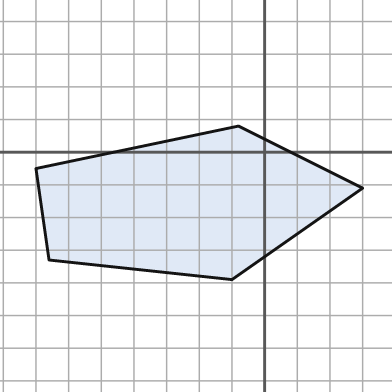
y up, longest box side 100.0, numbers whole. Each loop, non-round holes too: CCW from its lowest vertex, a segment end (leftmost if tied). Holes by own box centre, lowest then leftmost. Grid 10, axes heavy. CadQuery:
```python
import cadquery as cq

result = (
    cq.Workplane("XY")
    .moveTo(-10.0, -39.0)
    .lineTo(30.0, -11.0)
    .lineTo(-8.0, 8.0)
    .lineTo(-70.0, -5.0)
    .lineTo(-66.0, -33.0)
    .close()
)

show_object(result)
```